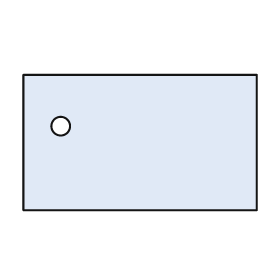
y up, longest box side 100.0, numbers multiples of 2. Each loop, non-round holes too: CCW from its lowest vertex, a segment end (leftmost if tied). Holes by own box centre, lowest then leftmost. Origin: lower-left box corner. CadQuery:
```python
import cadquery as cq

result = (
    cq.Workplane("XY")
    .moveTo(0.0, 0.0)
    .lineTo(100.0, 0.0)
    .lineTo(100.0, 58.0)
    .lineTo(0.0, 58.0)
    .close()
    .moveTo(16.0, 36.0)
    .circle(4.0)
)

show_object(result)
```